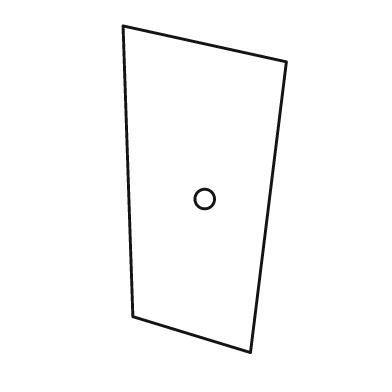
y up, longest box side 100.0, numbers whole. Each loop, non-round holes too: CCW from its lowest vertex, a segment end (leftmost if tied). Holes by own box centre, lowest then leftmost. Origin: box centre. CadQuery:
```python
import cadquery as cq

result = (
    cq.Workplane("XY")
    .moveTo(14.0, -50.0)
    .lineTo(25.0, 39.0)
    .lineTo(-25.0, 50.0)
    .lineTo(-22.0, -39.0)
    .close()
    .moveTo(0.0, -3.0)
    .circle(3.0)
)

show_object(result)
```